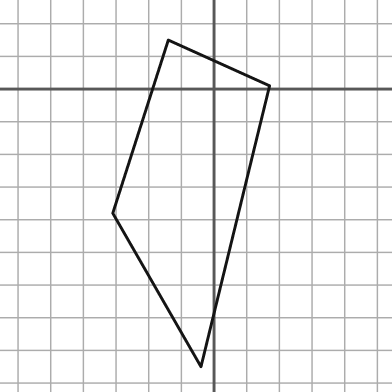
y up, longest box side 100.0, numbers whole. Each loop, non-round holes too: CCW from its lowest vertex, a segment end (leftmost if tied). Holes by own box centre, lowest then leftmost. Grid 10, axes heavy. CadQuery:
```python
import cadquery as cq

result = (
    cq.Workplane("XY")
    .moveTo(-4.0, -85.0)
    .lineTo(17.0, 1.0)
    .lineTo(-14.0, 15.0)
    .lineTo(-31.0, -38.0)
    .close()
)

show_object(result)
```